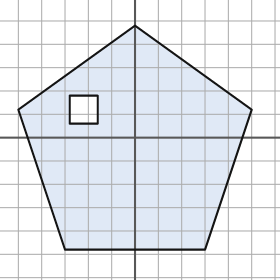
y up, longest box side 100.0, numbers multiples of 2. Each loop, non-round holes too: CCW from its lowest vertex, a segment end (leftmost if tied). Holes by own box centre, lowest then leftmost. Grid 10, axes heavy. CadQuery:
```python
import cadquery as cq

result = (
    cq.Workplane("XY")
    .moveTo(-30.0, -48.0)
    .lineTo(30.0, -48.0)
    .lineTo(50.0, 12.0)
    .lineTo(0.0, 48.0)
    .lineTo(-50.0, 12.0)
    .close()
    .moveTo(-28.0, 6.0)
    .lineTo(-16.0, 6.0)
    .lineTo(-16.0, 18.0)
    .lineTo(-28.0, 18.0)
    .close()
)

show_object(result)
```